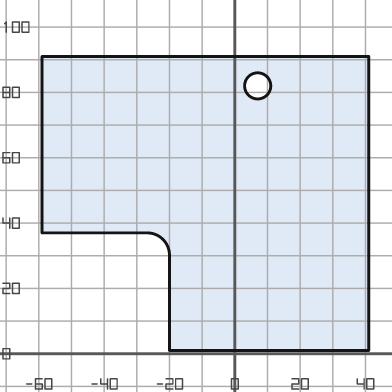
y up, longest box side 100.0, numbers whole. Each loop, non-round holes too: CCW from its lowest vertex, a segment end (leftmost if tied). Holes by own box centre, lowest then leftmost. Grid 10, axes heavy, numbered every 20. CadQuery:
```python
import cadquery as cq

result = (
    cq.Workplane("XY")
    .moveTo(-20.0, 1.0)
    .lineTo(41.0, 1.0)
    .lineTo(41.0, 91.0)
    .lineTo(-59.0, 91.0)
    .lineTo(-59.0, 37.0)
    .lineTo(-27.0, 37.0)
    .threePointArc((-22.0, 35.0), (-20.0, 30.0))
    .close()
    .moveTo(7.0, 82.0)
    .circle(4.0)
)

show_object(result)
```